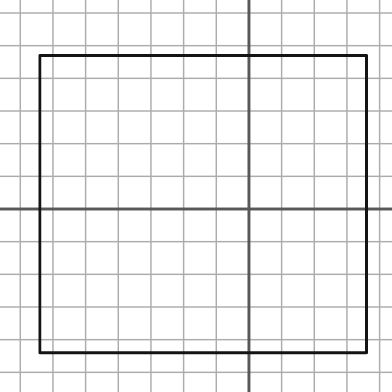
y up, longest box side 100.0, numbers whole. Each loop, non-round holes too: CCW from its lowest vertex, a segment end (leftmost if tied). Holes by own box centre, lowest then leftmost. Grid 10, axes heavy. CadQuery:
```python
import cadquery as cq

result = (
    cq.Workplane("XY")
    .moveTo(-64.0, -44.0)
    .lineTo(36.0, -44.0)
    .lineTo(36.0, 47.0)
    .lineTo(-64.0, 47.0)
    .close()
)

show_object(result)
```